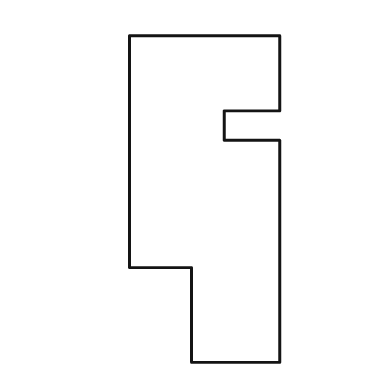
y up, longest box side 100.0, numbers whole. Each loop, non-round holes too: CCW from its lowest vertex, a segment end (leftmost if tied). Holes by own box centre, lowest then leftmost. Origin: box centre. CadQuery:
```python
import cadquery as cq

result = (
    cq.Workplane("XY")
    .moveTo(-4.0, -50.0)
    .lineTo(23.0, -50.0)
    .lineTo(23.0, 18.0)
    .lineTo(6.0, 18.0)
    .lineTo(6.0, 27.0)
    .lineTo(23.0, 27.0)
    .lineTo(23.0, 50.0)
    .lineTo(-23.0, 50.0)
    .lineTo(-23.0, -21.0)
    .lineTo(-4.0, -21.0)
    .close()
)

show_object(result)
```